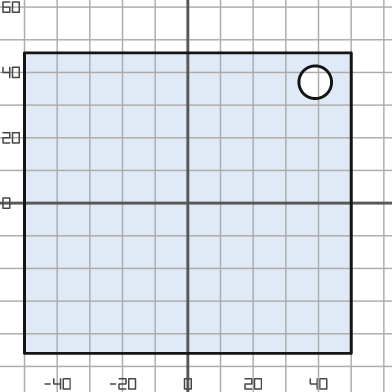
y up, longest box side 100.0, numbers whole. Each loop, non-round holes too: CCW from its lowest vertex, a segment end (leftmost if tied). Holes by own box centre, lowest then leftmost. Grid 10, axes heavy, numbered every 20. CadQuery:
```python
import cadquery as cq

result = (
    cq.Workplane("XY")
    .moveTo(-50.0, -46.0)
    .lineTo(50.0, -46.0)
    .lineTo(50.0, 46.0)
    .lineTo(-50.0, 46.0)
    .close()
    .moveTo(39.0, 37.0)
    .circle(5.0)
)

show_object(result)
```